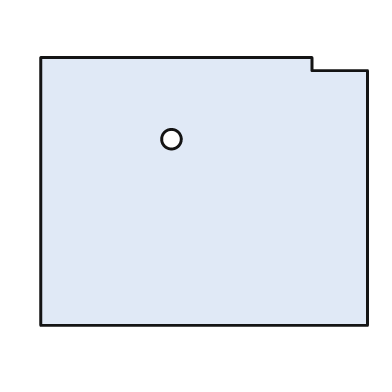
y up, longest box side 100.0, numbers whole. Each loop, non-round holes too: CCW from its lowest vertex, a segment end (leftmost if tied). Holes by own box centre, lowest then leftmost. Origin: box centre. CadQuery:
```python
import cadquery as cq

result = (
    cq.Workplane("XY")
    .moveTo(-50.0, -41.0)
    .lineTo(50.0, -41.0)
    .lineTo(50.0, 37.0)
    .lineTo(33.0, 37.0)
    .lineTo(33.0, 41.0)
    .lineTo(-50.0, 41.0)
    .close()
    .moveTo(-10.0, 16.0)
    .circle(3.0)
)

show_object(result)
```